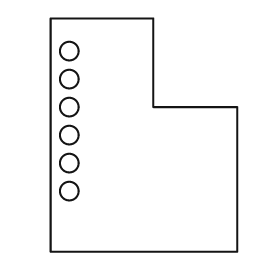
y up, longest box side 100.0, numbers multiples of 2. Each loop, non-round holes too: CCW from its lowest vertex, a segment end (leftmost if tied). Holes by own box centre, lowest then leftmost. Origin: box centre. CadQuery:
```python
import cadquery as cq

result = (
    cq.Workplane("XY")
    .moveTo(-40.0, -50.0)
    .lineTo(40.0, -50.0)
    .lineTo(40.0, 12.0)
    .lineTo(4.0, 12.0)
    .lineTo(4.0, 50.0)
    .lineTo(-40.0, 50.0)
    .close()
    .moveTo(-32.0, -24.0)
    .circle(4.0)
    .moveTo(-32.0, -12.0)
    .circle(4.0)
    .moveTo(-32.0, 0.0)
    .circle(4.0)
    .moveTo(-32.0, 12.0)
    .circle(4.0)
    .moveTo(-32.0, 24.0)
    .circle(4.0)
    .moveTo(-32.0, 36.0)
    .circle(4.0)
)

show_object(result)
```